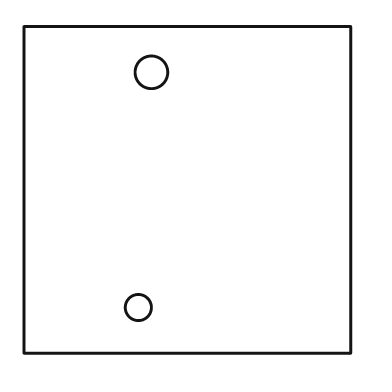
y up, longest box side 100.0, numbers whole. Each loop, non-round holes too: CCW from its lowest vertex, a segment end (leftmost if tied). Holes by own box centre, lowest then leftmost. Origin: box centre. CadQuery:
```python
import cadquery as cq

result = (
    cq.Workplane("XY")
    .moveTo(-50.0, -50.0)
    .lineTo(50.0, -50.0)
    .lineTo(50.0, 50.0)
    .lineTo(-50.0, 50.0)
    .close()
    .moveTo(-15.0, -36.0)
    .circle(4.0)
    .moveTo(-11.0, 36.0)
    .circle(5.0)
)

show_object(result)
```